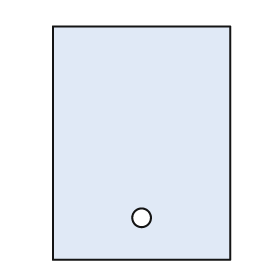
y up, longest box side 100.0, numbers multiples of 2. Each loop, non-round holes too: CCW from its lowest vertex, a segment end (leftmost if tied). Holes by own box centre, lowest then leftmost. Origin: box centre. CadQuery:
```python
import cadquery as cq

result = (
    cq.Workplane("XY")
    .moveTo(-38.0, -50.0)
    .lineTo(38.0, -50.0)
    .lineTo(38.0, 50.0)
    .lineTo(-38.0, 50.0)
    .close()
    .moveTo(0.0, -32.0)
    .circle(4.0)
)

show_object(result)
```